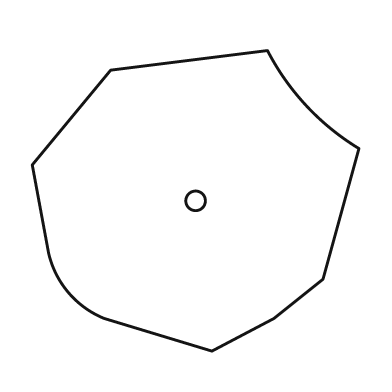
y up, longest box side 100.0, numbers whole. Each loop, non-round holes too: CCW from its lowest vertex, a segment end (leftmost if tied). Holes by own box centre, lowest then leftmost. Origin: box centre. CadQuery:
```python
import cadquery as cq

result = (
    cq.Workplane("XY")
    .moveTo(5.0, -46.0)
    .lineTo(24.0, -36.0)
    .lineTo(39.0, -24.0)
    .lineTo(50.0, 16.0)
    .threePointArc((34.0, 29.0), (22.0, 46.0))
    .lineTo(-26.0, 40.0)
    .lineTo(-50.0, 11.0)
    .lineTo(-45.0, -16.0)
    .threePointArc((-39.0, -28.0), (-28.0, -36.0))
    .close()
    .moveTo(0.0, 0.0)
    .circle(3.0)
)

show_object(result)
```